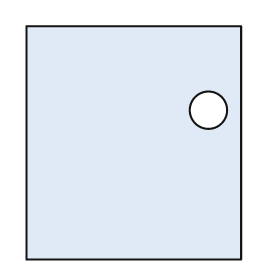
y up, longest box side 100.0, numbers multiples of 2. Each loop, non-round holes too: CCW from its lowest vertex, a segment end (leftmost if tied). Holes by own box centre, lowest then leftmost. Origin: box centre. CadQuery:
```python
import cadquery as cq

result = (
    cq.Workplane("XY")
    .moveTo(-46.0, -50.0)
    .lineTo(46.0, -50.0)
    .lineTo(46.0, 50.0)
    .lineTo(-46.0, 50.0)
    .close()
    .moveTo(32.0, 14.0)
    .circle(8.0)
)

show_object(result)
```